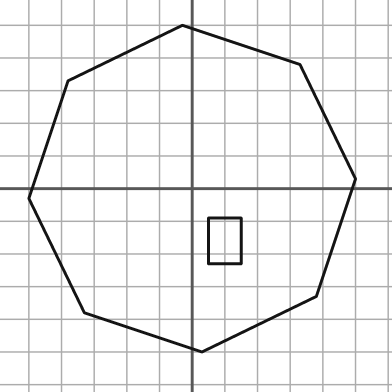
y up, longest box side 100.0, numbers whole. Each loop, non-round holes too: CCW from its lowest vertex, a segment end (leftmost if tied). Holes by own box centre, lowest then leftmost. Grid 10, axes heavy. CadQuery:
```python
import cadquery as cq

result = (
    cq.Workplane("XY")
    .moveTo(3.0, -50.0)
    .lineTo(38.0, -33.0)
    .lineTo(50.0, 3.0)
    .lineTo(33.0, 38.0)
    .lineTo(-3.0, 50.0)
    .lineTo(-38.0, 33.0)
    .lineTo(-50.0, -3.0)
    .lineTo(-33.0, -38.0)
    .close()
    .moveTo(5.0, -23.0)
    .lineTo(15.0, -23.0)
    .lineTo(15.0, -9.0)
    .lineTo(5.0, -9.0)
    .close()
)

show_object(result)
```